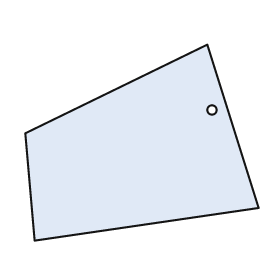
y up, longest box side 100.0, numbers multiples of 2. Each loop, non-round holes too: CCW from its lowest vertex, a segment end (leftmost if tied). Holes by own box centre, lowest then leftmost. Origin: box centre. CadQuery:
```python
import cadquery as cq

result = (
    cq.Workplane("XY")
    .moveTo(-46.0, -42.0)
    .lineTo(50.0, -28.0)
    .lineTo(28.0, 42.0)
    .lineTo(-50.0, 4.0)
    .close()
    .moveTo(30.0, 14.0)
    .circle(2.0)
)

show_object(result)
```